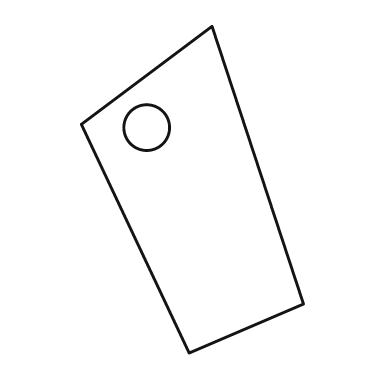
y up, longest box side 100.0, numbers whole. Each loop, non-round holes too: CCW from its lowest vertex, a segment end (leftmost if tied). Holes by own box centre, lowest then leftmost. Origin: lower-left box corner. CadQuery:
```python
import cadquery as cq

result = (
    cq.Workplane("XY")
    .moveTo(33.0, 0.0)
    .lineTo(68.0, 15.0)
    .lineTo(40.0, 100.0)
    .lineTo(0.0, 70.0)
    .close()
    .moveTo(20.0, 69.0)
    .circle(7.0)
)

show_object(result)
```